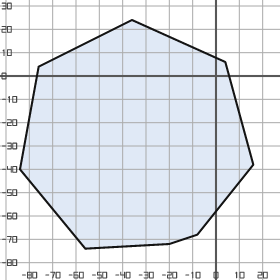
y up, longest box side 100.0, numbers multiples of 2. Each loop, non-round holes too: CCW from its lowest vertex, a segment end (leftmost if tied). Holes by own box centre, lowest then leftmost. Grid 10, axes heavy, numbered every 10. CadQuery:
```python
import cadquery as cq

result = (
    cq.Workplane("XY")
    .moveTo(-56.0, -74.0)
    .lineTo(-20.0, -72.0)
    .lineTo(-8.0, -68.0)
    .lineTo(16.0, -38.0)
    .lineTo(4.0, 6.0)
    .lineTo(-36.0, 24.0)
    .lineTo(-76.0, 4.0)
    .lineTo(-84.0, -40.0)
    .close()
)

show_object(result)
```